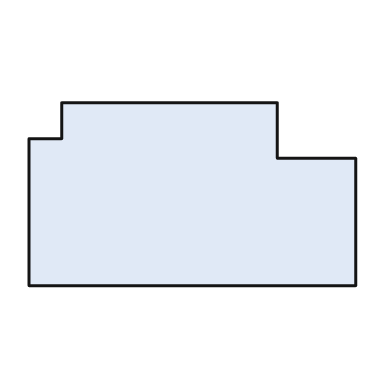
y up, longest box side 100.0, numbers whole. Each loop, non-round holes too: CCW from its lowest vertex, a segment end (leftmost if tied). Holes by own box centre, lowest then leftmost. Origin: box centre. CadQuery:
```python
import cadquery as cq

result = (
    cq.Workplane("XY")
    .moveTo(-50.0, -28.0)
    .lineTo(50.0, -28.0)
    .lineTo(50.0, 11.0)
    .lineTo(26.0, 11.0)
    .lineTo(26.0, 28.0)
    .lineTo(-40.0, 28.0)
    .lineTo(-40.0, 17.0)
    .lineTo(-50.0, 17.0)
    .close()
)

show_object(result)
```